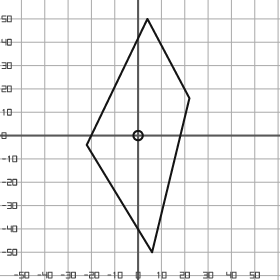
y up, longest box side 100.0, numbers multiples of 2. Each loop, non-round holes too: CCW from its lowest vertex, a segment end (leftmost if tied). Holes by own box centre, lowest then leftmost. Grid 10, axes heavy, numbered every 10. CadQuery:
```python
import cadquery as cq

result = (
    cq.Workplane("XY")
    .moveTo(6.0, -50.0)
    .lineTo(22.0, 16.0)
    .lineTo(4.0, 50.0)
    .lineTo(-22.0, -4.0)
    .close()
    .moveTo(0.0, 0.0)
    .circle(2.0)
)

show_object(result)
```